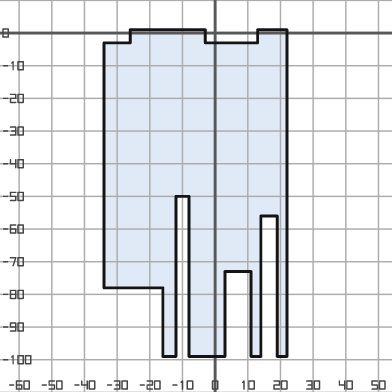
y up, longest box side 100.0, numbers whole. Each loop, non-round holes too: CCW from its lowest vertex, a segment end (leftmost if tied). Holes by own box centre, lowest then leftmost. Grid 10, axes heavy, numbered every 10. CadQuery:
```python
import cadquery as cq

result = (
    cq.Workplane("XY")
    .moveTo(-16.0, -99.0)
    .lineTo(-12.0, -99.0)
    .lineTo(-12.0, -50.0)
    .lineTo(-8.0, -50.0)
    .lineTo(-8.0, -99.0)
    .lineTo(3.0, -99.0)
    .lineTo(3.0, -73.0)
    .lineTo(11.0, -73.0)
    .lineTo(11.0, -99.0)
    .lineTo(14.0, -99.0)
    .lineTo(14.0, -56.0)
    .lineTo(19.0, -56.0)
    .lineTo(19.0, -99.0)
    .lineTo(22.0, -99.0)
    .lineTo(22.0, 1.0)
    .lineTo(13.0, 1.0)
    .lineTo(13.0, -3.0)
    .lineTo(-3.0, -3.0)
    .lineTo(-3.0, 1.0)
    .lineTo(-26.0, 1.0)
    .lineTo(-26.0, -3.0)
    .lineTo(-34.0, -3.0)
    .lineTo(-34.0, -78.0)
    .lineTo(-16.0, -78.0)
    .close()
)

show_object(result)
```